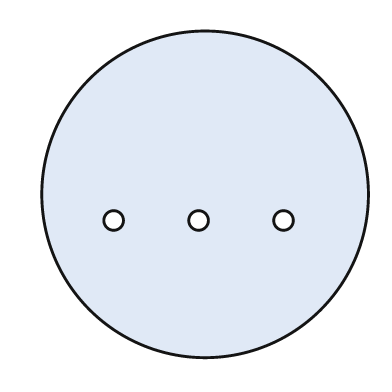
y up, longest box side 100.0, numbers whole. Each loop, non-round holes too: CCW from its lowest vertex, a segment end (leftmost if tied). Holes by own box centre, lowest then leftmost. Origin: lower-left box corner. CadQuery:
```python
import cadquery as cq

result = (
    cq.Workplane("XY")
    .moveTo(50.0, 50.0)
    .circle(50.0)
    .moveTo(22.0, 42.0)
    .circle(3.0)
    .moveTo(48.0, 42.0)
    .circle(3.0)
    .moveTo(74.0, 42.0)
    .circle(3.0)
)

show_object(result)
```